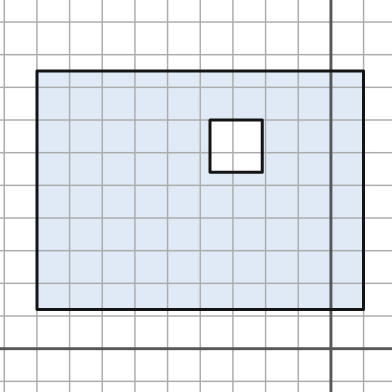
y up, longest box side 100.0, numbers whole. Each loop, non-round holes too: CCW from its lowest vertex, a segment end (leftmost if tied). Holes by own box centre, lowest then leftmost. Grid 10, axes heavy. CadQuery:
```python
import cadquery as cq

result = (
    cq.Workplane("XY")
    .moveTo(-90.0, 12.0)
    .lineTo(10.0, 12.0)
    .lineTo(10.0, 85.0)
    .lineTo(-90.0, 85.0)
    .close()
    .moveTo(-37.0, 54.0)
    .lineTo(-21.0, 54.0)
    .lineTo(-21.0, 70.0)
    .lineTo(-37.0, 70.0)
    .close()
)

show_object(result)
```